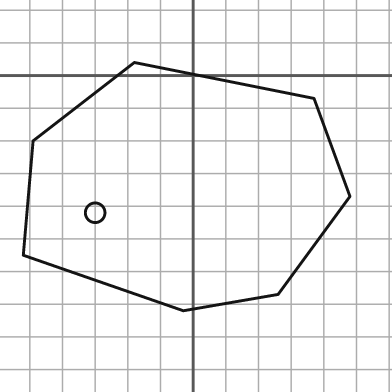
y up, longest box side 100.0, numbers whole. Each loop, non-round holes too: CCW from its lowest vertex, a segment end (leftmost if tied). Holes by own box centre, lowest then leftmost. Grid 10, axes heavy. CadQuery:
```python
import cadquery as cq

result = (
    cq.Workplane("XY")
    .moveTo(-3.0, -72.0)
    .lineTo(26.0, -67.0)
    .lineTo(48.0, -37.0)
    .lineTo(37.0, -7.0)
    .lineTo(-18.0, 4.0)
    .lineTo(-49.0, -20.0)
    .lineTo(-52.0, -55.0)
    .close()
    .moveTo(-30.0, -42.0)
    .circle(3.0)
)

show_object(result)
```